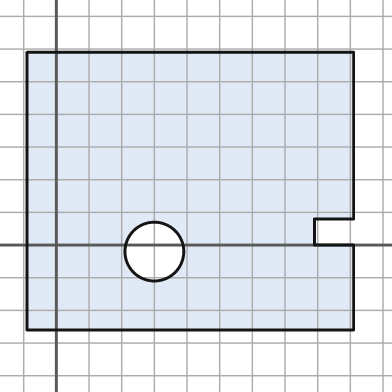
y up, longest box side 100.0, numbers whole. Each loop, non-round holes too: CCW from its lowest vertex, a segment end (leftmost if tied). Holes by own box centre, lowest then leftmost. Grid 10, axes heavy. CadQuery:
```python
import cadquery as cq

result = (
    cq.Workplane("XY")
    .moveTo(-9.0, -26.0)
    .lineTo(91.0, -26.0)
    .lineTo(91.0, 0.0)
    .lineTo(79.0, 0.0)
    .lineTo(79.0, 8.0)
    .lineTo(91.0, 8.0)
    .lineTo(91.0, 59.0)
    .lineTo(-9.0, 59.0)
    .close()
    .moveTo(30.0, -2.0)
    .circle(9.0)
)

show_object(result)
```